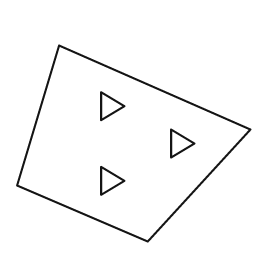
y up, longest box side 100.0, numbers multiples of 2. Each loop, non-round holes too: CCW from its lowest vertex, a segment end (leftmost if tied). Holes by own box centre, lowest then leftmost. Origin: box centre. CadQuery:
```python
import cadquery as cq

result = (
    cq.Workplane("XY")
    .moveTo(6.0, -42.0)
    .lineTo(50.0, 6.0)
    .lineTo(-32.0, 42.0)
    .lineTo(-50.0, -18.0)
    .close()
    .moveTo(-14.0, -22.0)
    .lineTo(-4.0, -16.0)
    .lineTo(-14.0, -10.0)
    .close()
    .moveTo(16.0, -6.0)
    .lineTo(26.0, 0.0)
    .lineTo(16.0, 6.0)
    .close()
    .moveTo(-14.0, 10.0)
    .lineTo(-4.0, 16.0)
    .lineTo(-14.0, 22.0)
    .close()
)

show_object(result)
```